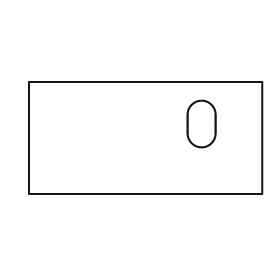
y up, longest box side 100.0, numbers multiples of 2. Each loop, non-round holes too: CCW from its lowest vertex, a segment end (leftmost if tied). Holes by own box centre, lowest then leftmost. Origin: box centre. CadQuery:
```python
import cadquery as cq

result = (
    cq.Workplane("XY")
    .moveTo(-50.0, -24.0)
    .lineTo(50.0, -24.0)
    .lineTo(50.0, 24.0)
    .lineTo(-50.0, 24.0)
    .close()
    .moveTo(18.0, 2.0)
    .threePointArc((24.0, -4.0), (30.0, 2.0))
    .lineTo(30.0, 10.0)
    .threePointArc((24.0, 16.0), (18.0, 10.0))
    .close()
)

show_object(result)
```